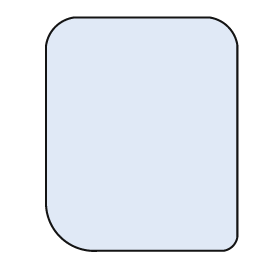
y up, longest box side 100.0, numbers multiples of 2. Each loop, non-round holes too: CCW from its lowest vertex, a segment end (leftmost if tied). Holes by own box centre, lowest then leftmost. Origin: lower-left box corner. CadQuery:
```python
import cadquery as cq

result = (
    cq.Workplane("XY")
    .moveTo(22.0, 0.0)
    .lineTo(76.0, 0.0)
    .threePointArc((80.0, 2.0), (82.0, 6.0))
    .lineTo(82.0, 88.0)
    .threePointArc((78.0, 96.0), (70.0, 100.0))
    .lineTo(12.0, 100.0)
    .threePointArc((4.0, 96.0), (0.0, 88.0))
    .lineTo(0.0, 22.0)
    .threePointArc((6.0, 6.0), (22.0, 0.0))
    .close()
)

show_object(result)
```